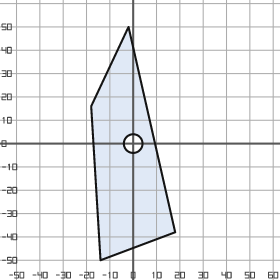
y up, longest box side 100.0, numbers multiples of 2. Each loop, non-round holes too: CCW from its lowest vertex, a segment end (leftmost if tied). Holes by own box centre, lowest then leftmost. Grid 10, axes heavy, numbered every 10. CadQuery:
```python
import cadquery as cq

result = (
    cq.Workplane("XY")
    .moveTo(-14.0, -50.0)
    .lineTo(18.0, -38.0)
    .lineTo(-2.0, 50.0)
    .lineTo(-18.0, 16.0)
    .close()
    .moveTo(0.0, 0.0)
    .circle(4.0)
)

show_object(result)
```